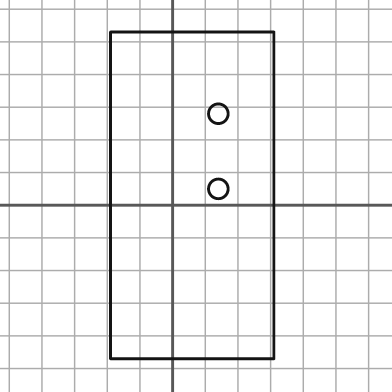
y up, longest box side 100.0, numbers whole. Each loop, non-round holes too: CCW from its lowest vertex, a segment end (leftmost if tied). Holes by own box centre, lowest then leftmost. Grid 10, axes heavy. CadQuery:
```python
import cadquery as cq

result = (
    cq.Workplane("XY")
    .moveTo(-19.0, -47.0)
    .lineTo(31.0, -47.0)
    .lineTo(31.0, 53.0)
    .lineTo(-19.0, 53.0)
    .close()
    .moveTo(14.0, 5.0)
    .circle(3.0)
    .moveTo(14.0, 28.0)
    .circle(3.0)
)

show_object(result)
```